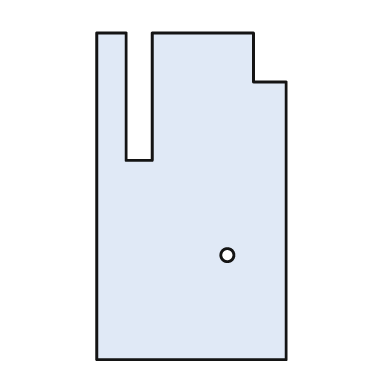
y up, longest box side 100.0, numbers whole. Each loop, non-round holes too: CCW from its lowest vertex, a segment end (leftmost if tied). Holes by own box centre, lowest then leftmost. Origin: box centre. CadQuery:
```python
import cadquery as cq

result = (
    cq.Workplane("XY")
    .moveTo(-29.0, -50.0)
    .lineTo(29.0, -50.0)
    .lineTo(29.0, 35.0)
    .lineTo(19.0, 35.0)
    .lineTo(19.0, 50.0)
    .lineTo(-12.0, 50.0)
    .lineTo(-12.0, 11.0)
    .lineTo(-20.0, 11.0)
    .lineTo(-20.0, 50.0)
    .lineTo(-29.0, 50.0)
    .close()
    .moveTo(11.0, -18.0)
    .circle(2.0)
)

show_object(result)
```